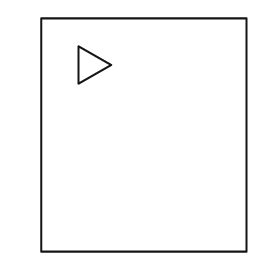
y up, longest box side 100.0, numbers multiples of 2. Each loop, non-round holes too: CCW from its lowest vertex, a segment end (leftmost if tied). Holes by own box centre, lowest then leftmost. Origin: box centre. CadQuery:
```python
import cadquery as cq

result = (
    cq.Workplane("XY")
    .moveTo(-44.0, -50.0)
    .lineTo(44.0, -50.0)
    .lineTo(44.0, 50.0)
    .lineTo(-44.0, 50.0)
    .close()
    .moveTo(-28.0, 22.0)
    .lineTo(-14.0, 30.0)
    .lineTo(-28.0, 38.0)
    .close()
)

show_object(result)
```